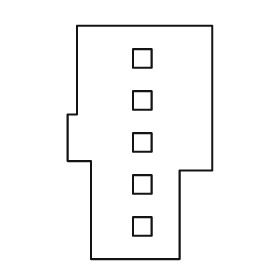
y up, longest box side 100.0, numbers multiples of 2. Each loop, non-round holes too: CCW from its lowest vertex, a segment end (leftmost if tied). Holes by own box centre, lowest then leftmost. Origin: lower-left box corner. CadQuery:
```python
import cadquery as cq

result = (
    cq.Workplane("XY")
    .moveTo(10.0, 0.0)
    .lineTo(48.0, 0.0)
    .lineTo(48.0, 38.0)
    .lineTo(62.0, 38.0)
    .lineTo(62.0, 100.0)
    .lineTo(4.0, 100.0)
    .lineTo(4.0, 62.0)
    .lineTo(0.0, 62.0)
    .lineTo(0.0, 42.0)
    .lineTo(10.0, 42.0)
    .close()
    .moveTo(28.0, 10.0)
    .lineTo(36.0, 10.0)
    .lineTo(36.0, 18.0)
    .lineTo(28.0, 18.0)
    .close()
    .moveTo(28.0, 28.0)
    .lineTo(36.0, 28.0)
    .lineTo(36.0, 36.0)
    .lineTo(28.0, 36.0)
    .close()
    .moveTo(28.0, 46.0)
    .lineTo(36.0, 46.0)
    .lineTo(36.0, 54.0)
    .lineTo(28.0, 54.0)
    .close()
    .moveTo(28.0, 64.0)
    .lineTo(36.0, 64.0)
    .lineTo(36.0, 72.0)
    .lineTo(28.0, 72.0)
    .close()
    .moveTo(28.0, 82.0)
    .lineTo(36.0, 82.0)
    .lineTo(36.0, 90.0)
    .lineTo(28.0, 90.0)
    .close()
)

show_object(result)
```